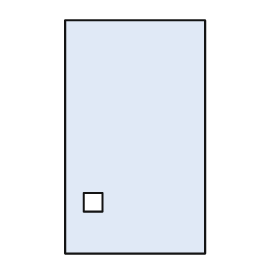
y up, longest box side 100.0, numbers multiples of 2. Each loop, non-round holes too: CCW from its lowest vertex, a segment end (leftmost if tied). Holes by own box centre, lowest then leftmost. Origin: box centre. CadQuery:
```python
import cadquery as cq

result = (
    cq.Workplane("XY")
    .moveTo(-30.0, -50.0)
    .lineTo(30.0, -50.0)
    .lineTo(30.0, 50.0)
    .lineTo(-30.0, 50.0)
    .close()
    .moveTo(-22.0, -32.0)
    .lineTo(-14.0, -32.0)
    .lineTo(-14.0, -24.0)
    .lineTo(-22.0, -24.0)
    .close()
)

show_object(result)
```